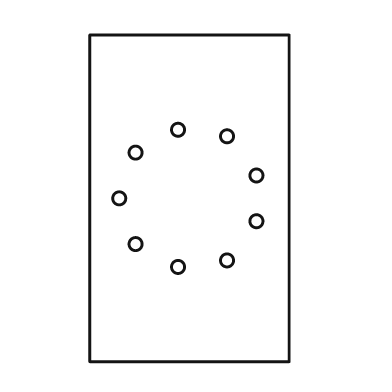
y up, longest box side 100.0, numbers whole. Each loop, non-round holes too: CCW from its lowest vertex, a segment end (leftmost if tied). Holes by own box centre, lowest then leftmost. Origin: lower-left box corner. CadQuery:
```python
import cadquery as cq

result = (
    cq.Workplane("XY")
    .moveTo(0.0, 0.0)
    .lineTo(61.0, 0.0)
    .lineTo(61.0, 100.0)
    .lineTo(0.0, 100.0)
    .close()
    .moveTo(27.0, 29.0)
    .circle(2.0)
    .moveTo(42.0, 31.0)
    .circle(2.0)
    .moveTo(14.0, 36.0)
    .circle(2.0)
    .moveTo(51.0, 43.0)
    .circle(2.0)
    .moveTo(9.0, 50.0)
    .circle(2.0)
    .moveTo(51.0, 57.0)
    .circle(2.0)
    .moveTo(14.0, 64.0)
    .circle(2.0)
    .moveTo(42.0, 69.0)
    .circle(2.0)
    .moveTo(27.0, 71.0)
    .circle(2.0)
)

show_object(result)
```